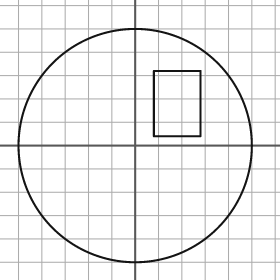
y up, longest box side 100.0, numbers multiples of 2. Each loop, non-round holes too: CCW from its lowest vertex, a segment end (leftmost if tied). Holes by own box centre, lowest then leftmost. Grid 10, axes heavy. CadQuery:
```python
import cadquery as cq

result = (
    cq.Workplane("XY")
    .moveTo(0.0, 0.0)
    .circle(50.0)
    .moveTo(8.0, 4.0)
    .lineTo(28.0, 4.0)
    .lineTo(28.0, 32.0)
    .lineTo(8.0, 32.0)
    .close()
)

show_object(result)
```